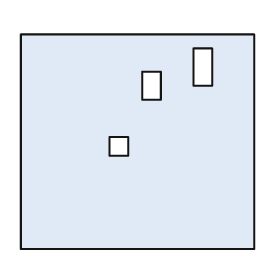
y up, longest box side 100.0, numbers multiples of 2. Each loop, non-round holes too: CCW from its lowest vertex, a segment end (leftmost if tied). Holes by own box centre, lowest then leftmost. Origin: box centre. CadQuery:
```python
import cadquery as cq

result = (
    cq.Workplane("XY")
    .moveTo(-50.0, -46.0)
    .lineTo(50.0, -46.0)
    .lineTo(50.0, 46.0)
    .lineTo(-50.0, 46.0)
    .close()
    .moveTo(-12.0, -6.0)
    .lineTo(-4.0, -6.0)
    .lineTo(-4.0, 2.0)
    .lineTo(-12.0, 2.0)
    .close()
    .moveTo(2.0, 18.0)
    .lineTo(10.0, 18.0)
    .lineTo(10.0, 30.0)
    .lineTo(2.0, 30.0)
    .close()
    .moveTo(24.0, 24.0)
    .lineTo(32.0, 24.0)
    .lineTo(32.0, 40.0)
    .lineTo(24.0, 40.0)
    .close()
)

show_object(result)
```